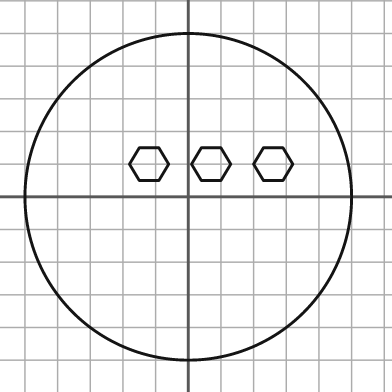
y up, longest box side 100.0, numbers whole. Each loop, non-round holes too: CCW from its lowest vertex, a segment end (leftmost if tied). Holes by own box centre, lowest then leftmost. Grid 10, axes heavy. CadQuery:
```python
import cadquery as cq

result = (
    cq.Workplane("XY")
    .moveTo(0.0, 0.0)
    .circle(50.0)
    .moveTo(-15.0, 5.0)
    .lineTo(-9.0, 5.0)
    .lineTo(-6.0, 10.0)
    .lineTo(-9.0, 15.0)
    .lineTo(-15.0, 15.0)
    .lineTo(-18.0, 10.0)
    .close()
    .moveTo(4.0, 5.0)
    .lineTo(10.0, 5.0)
    .lineTo(13.0, 10.0)
    .lineTo(10.0, 15.0)
    .lineTo(4.0, 15.0)
    .lineTo(1.0, 10.0)
    .close()
    .moveTo(23.0, 5.0)
    .lineTo(29.0, 5.0)
    .lineTo(32.0, 10.0)
    .lineTo(29.0, 15.0)
    .lineTo(23.0, 15.0)
    .lineTo(20.0, 10.0)
    .close()
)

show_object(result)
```